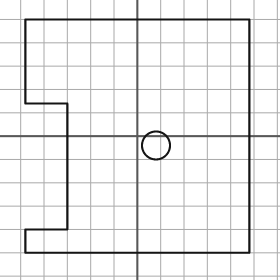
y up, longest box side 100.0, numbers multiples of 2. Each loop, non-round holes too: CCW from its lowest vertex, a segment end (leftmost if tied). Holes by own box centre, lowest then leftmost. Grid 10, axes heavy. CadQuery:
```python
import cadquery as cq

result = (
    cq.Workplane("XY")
    .moveTo(-48.0, -50.0)
    .lineTo(48.0, -50.0)
    .lineTo(48.0, 50.0)
    .lineTo(-48.0, 50.0)
    .lineTo(-48.0, 14.0)
    .lineTo(-30.0, 14.0)
    .lineTo(-30.0, -40.0)
    .lineTo(-48.0, -40.0)
    .close()
    .moveTo(8.0, -4.0)
    .circle(6.0)
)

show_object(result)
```